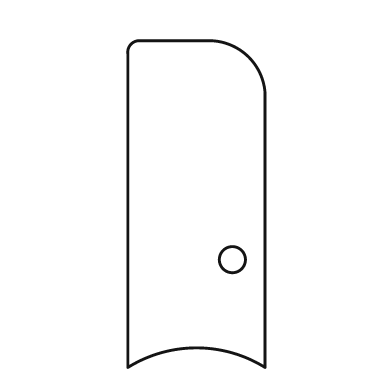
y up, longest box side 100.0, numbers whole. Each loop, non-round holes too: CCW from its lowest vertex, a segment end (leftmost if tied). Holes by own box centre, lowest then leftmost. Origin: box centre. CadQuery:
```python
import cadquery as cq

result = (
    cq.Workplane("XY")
    .moveTo(-21.0, -50.0)
    .threePointArc((0.0, -44.0), (21.0, -50.0))
    .lineTo(21.0, 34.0)
    .threePointArc((16.0, 45.0), (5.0, 50.0))
    .lineTo(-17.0, 50.0)
    .threePointArc((-20.0, 49.0), (-21.0, 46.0))
    .close()
    .moveTo(11.0, -17.0)
    .circle(4.0)
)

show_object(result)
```